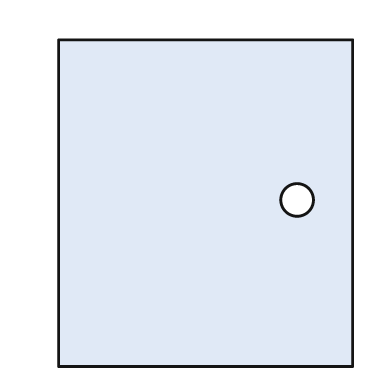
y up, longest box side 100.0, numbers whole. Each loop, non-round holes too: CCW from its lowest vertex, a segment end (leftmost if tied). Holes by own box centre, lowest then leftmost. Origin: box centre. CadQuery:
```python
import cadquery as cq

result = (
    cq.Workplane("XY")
    .moveTo(-45.0, -50.0)
    .lineTo(45.0, -50.0)
    .lineTo(45.0, 50.0)
    .lineTo(-45.0, 50.0)
    .close()
    .moveTo(28.0, 1.0)
    .circle(5.0)
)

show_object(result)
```